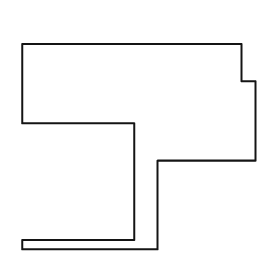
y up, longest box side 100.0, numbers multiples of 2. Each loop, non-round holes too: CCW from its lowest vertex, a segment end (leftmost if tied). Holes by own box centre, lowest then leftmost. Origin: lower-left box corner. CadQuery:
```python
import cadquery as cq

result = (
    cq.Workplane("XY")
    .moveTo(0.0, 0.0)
    .lineTo(58.0, 0.0)
    .lineTo(58.0, 38.0)
    .lineTo(100.0, 38.0)
    .lineTo(100.0, 72.0)
    .lineTo(94.0, 72.0)
    .lineTo(94.0, 88.0)
    .lineTo(0.0, 88.0)
    .lineTo(0.0, 54.0)
    .lineTo(48.0, 54.0)
    .lineTo(48.0, 4.0)
    .lineTo(0.0, 4.0)
    .close()
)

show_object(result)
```